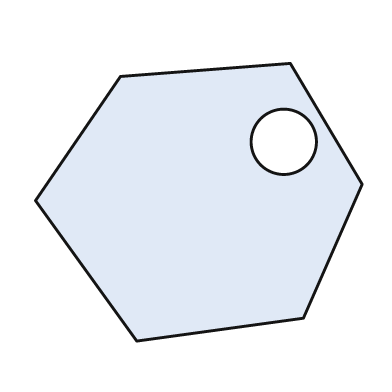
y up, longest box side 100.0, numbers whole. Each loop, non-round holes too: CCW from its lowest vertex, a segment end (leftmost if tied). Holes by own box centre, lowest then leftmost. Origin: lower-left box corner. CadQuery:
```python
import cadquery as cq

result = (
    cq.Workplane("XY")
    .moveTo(31.0, 0.0)
    .lineTo(82.0, 7.0)
    .lineTo(100.0, 48.0)
    .lineTo(78.0, 85.0)
    .lineTo(26.0, 81.0)
    .lineTo(0.0, 43.0)
    .close()
    .moveTo(76.0, 61.0)
    .circle(10.0)
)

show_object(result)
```